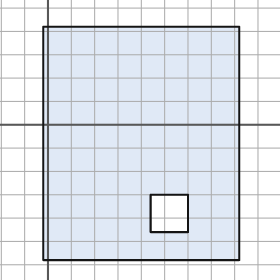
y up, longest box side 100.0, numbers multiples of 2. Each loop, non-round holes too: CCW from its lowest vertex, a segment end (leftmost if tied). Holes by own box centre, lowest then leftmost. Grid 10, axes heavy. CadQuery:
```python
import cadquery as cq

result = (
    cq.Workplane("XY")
    .moveTo(-2.0, -58.0)
    .lineTo(82.0, -58.0)
    .lineTo(82.0, 42.0)
    .lineTo(-2.0, 42.0)
    .close()
    .moveTo(44.0, -46.0)
    .lineTo(60.0, -46.0)
    .lineTo(60.0, -30.0)
    .lineTo(44.0, -30.0)
    .close()
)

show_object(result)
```